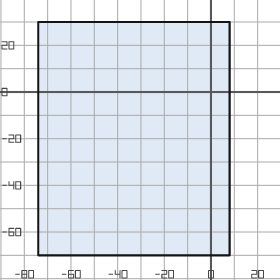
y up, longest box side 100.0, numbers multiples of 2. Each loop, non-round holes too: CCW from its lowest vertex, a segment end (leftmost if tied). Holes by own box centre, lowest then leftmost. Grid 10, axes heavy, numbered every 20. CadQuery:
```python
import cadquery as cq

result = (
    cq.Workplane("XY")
    .moveTo(-74.0, -70.0)
    .lineTo(8.0, -70.0)
    .lineTo(8.0, 30.0)
    .lineTo(-74.0, 30.0)
    .close()
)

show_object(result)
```